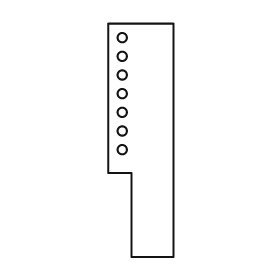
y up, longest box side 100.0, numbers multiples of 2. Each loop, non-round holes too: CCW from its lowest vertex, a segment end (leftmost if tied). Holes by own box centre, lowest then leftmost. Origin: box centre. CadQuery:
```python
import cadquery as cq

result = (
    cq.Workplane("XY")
    .moveTo(-4.0, -50.0)
    .lineTo(14.0, -50.0)
    .lineTo(14.0, 50.0)
    .lineTo(-14.0, 50.0)
    .lineTo(-14.0, -14.0)
    .lineTo(-4.0, -14.0)
    .close()
    .moveTo(-8.0, -4.0)
    .circle(2.0)
    .moveTo(-8.0, 4.0)
    .circle(2.0)
    .moveTo(-8.0, 12.0)
    .circle(2.0)
    .moveTo(-8.0, 20.0)
    .circle(2.0)
    .moveTo(-8.0, 28.0)
    .circle(2.0)
    .moveTo(-8.0, 36.0)
    .circle(2.0)
    .moveTo(-8.0, 44.0)
    .circle(2.0)
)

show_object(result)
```